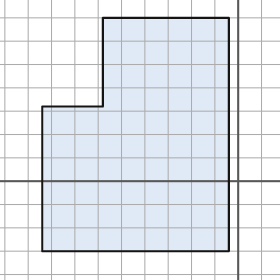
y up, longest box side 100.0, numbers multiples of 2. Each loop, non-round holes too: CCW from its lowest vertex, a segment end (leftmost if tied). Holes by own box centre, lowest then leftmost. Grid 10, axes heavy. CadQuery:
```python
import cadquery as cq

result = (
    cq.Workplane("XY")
    .moveTo(-84.0, -30.0)
    .lineTo(-4.0, -30.0)
    .lineTo(-4.0, 70.0)
    .lineTo(-58.0, 70.0)
    .lineTo(-58.0, 32.0)
    .lineTo(-84.0, 32.0)
    .close()
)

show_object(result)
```